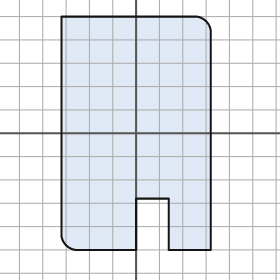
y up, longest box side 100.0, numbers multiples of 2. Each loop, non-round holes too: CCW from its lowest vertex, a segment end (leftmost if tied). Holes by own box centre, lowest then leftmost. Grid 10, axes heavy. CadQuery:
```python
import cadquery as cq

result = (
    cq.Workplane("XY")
    .moveTo(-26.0, -50.0)
    .lineTo(0.0, -50.0)
    .lineTo(0.0, -28.0)
    .lineTo(14.0, -28.0)
    .lineTo(14.0, -50.0)
    .lineTo(32.0, -50.0)
    .lineTo(32.0, 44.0)
    .threePointArc((30.0, 48.0), (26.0, 50.0))
    .lineTo(-32.0, 50.0)
    .lineTo(-32.0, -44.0)
    .threePointArc((-30.0, -48.0), (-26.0, -50.0))
    .close()
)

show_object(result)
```